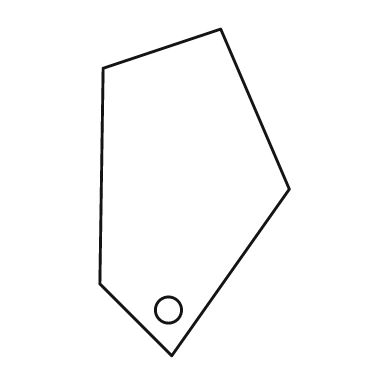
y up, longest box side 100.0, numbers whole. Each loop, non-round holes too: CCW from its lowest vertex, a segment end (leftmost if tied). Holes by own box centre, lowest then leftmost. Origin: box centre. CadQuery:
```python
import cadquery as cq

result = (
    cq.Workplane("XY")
    .moveTo(-7.0, -50.0)
    .lineTo(29.0, 1.0)
    .lineTo(8.0, 50.0)
    .lineTo(-28.0, 38.0)
    .lineTo(-29.0, -28.0)
    .close()
    .moveTo(-8.0, -36.0)
    .circle(4.0)
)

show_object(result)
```